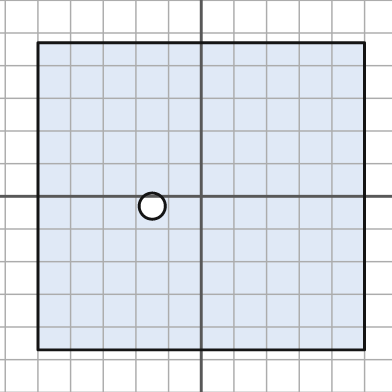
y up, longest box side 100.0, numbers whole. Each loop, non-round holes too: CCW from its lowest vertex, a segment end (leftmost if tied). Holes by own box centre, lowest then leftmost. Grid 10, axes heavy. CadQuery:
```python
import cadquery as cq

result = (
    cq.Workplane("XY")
    .moveTo(-50.0, -47.0)
    .lineTo(50.0, -47.0)
    .lineTo(50.0, 47.0)
    .lineTo(-50.0, 47.0)
    .close()
    .moveTo(-15.0, -3.0)
    .circle(4.0)
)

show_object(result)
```